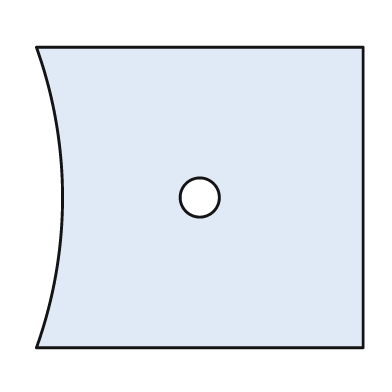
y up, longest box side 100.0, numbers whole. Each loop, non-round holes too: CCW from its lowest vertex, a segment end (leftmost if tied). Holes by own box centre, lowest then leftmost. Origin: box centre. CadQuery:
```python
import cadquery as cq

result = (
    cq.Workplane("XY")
    .moveTo(-50.0, -46.0)
    .lineTo(50.0, -46.0)
    .lineTo(50.0, 46.0)
    .lineTo(-50.0, 46.0)
    .threePointArc((-42.0, 0.0), (-50.0, -46.0))
    .close()
    .moveTo(0.0, 0.0)
    .circle(6.0)
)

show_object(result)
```